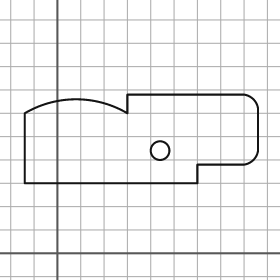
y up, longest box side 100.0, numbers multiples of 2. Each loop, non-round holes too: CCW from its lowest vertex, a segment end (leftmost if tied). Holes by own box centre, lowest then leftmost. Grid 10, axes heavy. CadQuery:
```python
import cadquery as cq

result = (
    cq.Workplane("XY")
    .moveTo(-14.0, 30.0)
    .lineTo(60.0, 30.0)
    .lineTo(60.0, 38.0)
    .lineTo(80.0, 38.0)
    .threePointArc((84.0, 40.0), (86.0, 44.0))
    .lineTo(86.0, 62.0)
    .threePointArc((84.0, 66.0), (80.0, 68.0))
    .lineTo(30.0, 68.0)
    .lineTo(30.0, 60.0)
    .threePointArc((8.0, 66.0), (-14.0, 60.0))
    .close()
    .moveTo(44.0, 44.0)
    .circle(4.0)
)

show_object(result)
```